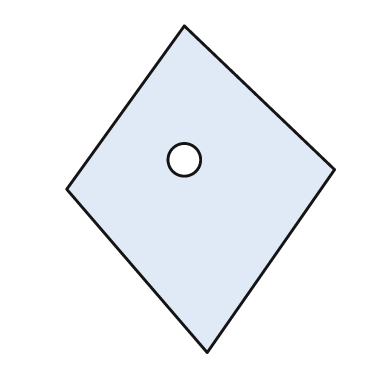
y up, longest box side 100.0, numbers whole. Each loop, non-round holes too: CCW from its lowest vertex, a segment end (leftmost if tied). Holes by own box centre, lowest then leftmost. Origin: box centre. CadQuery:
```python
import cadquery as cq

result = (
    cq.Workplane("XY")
    .moveTo(2.0, -50.0)
    .lineTo(41.0, 6.0)
    .lineTo(-5.0, 50.0)
    .lineTo(-41.0, 0.0)
    .close()
    .moveTo(-5.0, 9.0)
    .circle(5.0)
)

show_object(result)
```